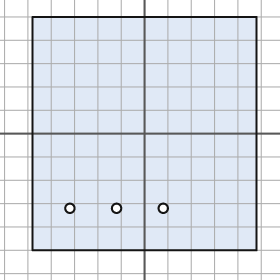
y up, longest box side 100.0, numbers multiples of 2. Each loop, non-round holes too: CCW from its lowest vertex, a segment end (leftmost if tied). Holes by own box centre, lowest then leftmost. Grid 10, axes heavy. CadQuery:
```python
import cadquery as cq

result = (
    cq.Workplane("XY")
    .moveTo(-48.0, -50.0)
    .lineTo(48.0, -50.0)
    .lineTo(48.0, 50.0)
    .lineTo(-48.0, 50.0)
    .close()
    .moveTo(-32.0, -32.0)
    .circle(2.0)
    .moveTo(-12.0, -32.0)
    .circle(2.0)
    .moveTo(8.0, -32.0)
    .circle(2.0)
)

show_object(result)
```